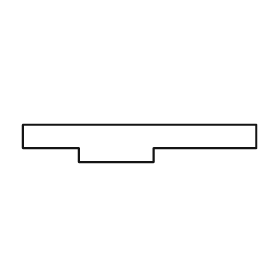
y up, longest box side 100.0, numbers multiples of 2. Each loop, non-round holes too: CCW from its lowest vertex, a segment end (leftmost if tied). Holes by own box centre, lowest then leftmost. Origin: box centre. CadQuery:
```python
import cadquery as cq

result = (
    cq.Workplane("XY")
    .moveTo(-26.0, -8.0)
    .lineTo(6.0, -8.0)
    .lineTo(6.0, -2.0)
    .lineTo(50.0, -2.0)
    .lineTo(50.0, 8.0)
    .lineTo(-50.0, 8.0)
    .lineTo(-50.0, -2.0)
    .lineTo(-26.0, -2.0)
    .close()
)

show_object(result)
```